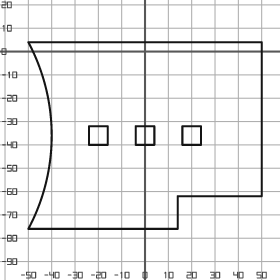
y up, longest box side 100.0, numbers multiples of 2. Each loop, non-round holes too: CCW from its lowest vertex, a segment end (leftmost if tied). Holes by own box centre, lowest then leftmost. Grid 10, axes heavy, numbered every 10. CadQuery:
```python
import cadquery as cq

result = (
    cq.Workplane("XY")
    .moveTo(-50.0, -76.0)
    .lineTo(14.0, -76.0)
    .lineTo(14.0, -62.0)
    .lineTo(50.0, -62.0)
    .lineTo(50.0, 4.0)
    .lineTo(-50.0, 4.0)
    .threePointArc((-40.0, -36.0), (-50.0, -76.0))
    .close()
    .moveTo(-24.0, -40.0)
    .lineTo(-16.0, -40.0)
    .lineTo(-16.0, -32.0)
    .lineTo(-24.0, -32.0)
    .close()
    .moveTo(-4.0, -40.0)
    .lineTo(4.0, -40.0)
    .lineTo(4.0, -32.0)
    .lineTo(-4.0, -32.0)
    .close()
    .moveTo(16.0, -40.0)
    .lineTo(24.0, -40.0)
    .lineTo(24.0, -32.0)
    .lineTo(16.0, -32.0)
    .close()
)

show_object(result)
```